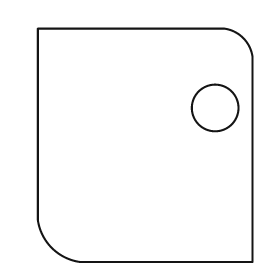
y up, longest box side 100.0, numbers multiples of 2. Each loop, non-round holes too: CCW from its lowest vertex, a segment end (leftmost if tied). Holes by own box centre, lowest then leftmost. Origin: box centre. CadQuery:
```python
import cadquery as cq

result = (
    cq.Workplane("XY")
    .moveTo(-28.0, -50.0)
    .lineTo(46.0, -50.0)
    .lineTo(46.0, 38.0)
    .threePointArc((42.0, 46.0), (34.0, 50.0))
    .lineTo(-46.0, 50.0)
    .lineTo(-46.0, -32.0)
    .threePointArc((-40.0, -44.0), (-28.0, -50.0))
    .close()
    .moveTo(30.0, 16.0)
    .circle(10.0)
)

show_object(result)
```